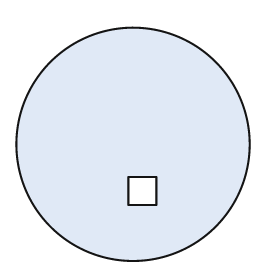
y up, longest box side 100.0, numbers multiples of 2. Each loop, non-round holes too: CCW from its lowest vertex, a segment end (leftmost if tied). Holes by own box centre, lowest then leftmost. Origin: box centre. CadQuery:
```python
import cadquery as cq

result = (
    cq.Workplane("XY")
    .moveTo(0.0, 0.0)
    .circle(50.0)
    .moveTo(-2.0, -26.0)
    .lineTo(10.0, -26.0)
    .lineTo(10.0, -14.0)
    .lineTo(-2.0, -14.0)
    .close()
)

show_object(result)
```